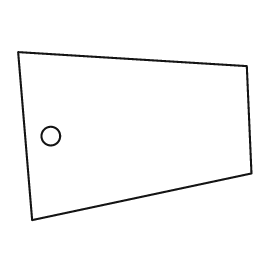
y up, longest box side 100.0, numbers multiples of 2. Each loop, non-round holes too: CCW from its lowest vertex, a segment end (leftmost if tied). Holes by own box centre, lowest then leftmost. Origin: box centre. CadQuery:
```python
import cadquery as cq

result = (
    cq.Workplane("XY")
    .moveTo(-44.0, -36.0)
    .lineTo(50.0, -16.0)
    .lineTo(48.0, 30.0)
    .lineTo(-50.0, 36.0)
    .close()
    .moveTo(-36.0, 0.0)
    .circle(4.0)
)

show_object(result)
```